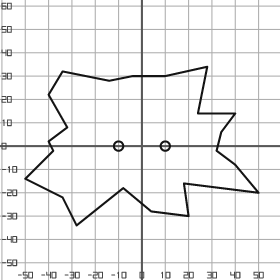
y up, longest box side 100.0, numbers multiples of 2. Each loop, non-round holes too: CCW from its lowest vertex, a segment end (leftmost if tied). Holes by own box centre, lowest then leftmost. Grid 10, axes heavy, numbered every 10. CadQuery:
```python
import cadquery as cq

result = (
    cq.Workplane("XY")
    .moveTo(-28.0, -34.0)
    .lineTo(-8.0, -18.0)
    .lineTo(4.0, -28.0)
    .lineTo(20.0, -30.0)
    .lineTo(18.0, -16.0)
    .lineTo(50.0, -20.0)
    .lineTo(40.0, -8.0)
    .lineTo(32.0, -2.0)
    .lineTo(34.0, 6.0)
    .lineTo(40.0, 14.0)
    .lineTo(24.0, 14.0)
    .lineTo(28.0, 34.0)
    .lineTo(10.0, 30.0)
    .lineTo(-4.0, 30.0)
    .lineTo(-14.0, 28.0)
    .lineTo(-34.0, 32.0)
    .lineTo(-40.0, 22.0)
    .lineTo(-32.0, 8.0)
    .lineTo(-40.0, 2.0)
    .lineTo(-38.0, -2.0)
    .lineTo(-50.0, -14.0)
    .lineTo(-34.0, -22.0)
    .close()
    .moveTo(-10.0, 0.0)
    .circle(2.0)
    .moveTo(10.0, 0.0)
    .circle(2.0)
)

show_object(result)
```